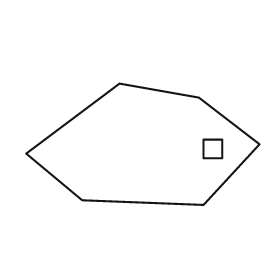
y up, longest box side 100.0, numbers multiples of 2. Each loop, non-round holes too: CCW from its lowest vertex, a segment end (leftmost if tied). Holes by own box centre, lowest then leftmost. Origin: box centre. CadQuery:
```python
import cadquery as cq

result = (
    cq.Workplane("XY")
    .moveTo(26.0, -26.0)
    .lineTo(50.0, 0.0)
    .lineTo(24.0, 20.0)
    .lineTo(-10.0, 26.0)
    .lineTo(-50.0, -4.0)
    .lineTo(-26.0, -24.0)
    .close()
    .moveTo(26.0, -6.0)
    .lineTo(34.0, -6.0)
    .lineTo(34.0, 2.0)
    .lineTo(26.0, 2.0)
    .close()
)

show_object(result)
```